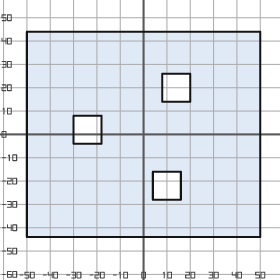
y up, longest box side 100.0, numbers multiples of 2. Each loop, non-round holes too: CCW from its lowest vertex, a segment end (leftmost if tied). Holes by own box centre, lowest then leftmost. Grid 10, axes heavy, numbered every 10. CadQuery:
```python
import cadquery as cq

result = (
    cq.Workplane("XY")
    .moveTo(-50.0, -44.0)
    .lineTo(50.0, -44.0)
    .lineTo(50.0, 44.0)
    .lineTo(-50.0, 44.0)
    .close()
    .moveTo(4.0, -28.0)
    .lineTo(16.0, -28.0)
    .lineTo(16.0, -16.0)
    .lineTo(4.0, -16.0)
    .close()
    .moveTo(-30.0, -4.0)
    .lineTo(-18.0, -4.0)
    .lineTo(-18.0, 8.0)
    .lineTo(-30.0, 8.0)
    .close()
    .moveTo(8.0, 14.0)
    .lineTo(20.0, 14.0)
    .lineTo(20.0, 26.0)
    .lineTo(8.0, 26.0)
    .close()
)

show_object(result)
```